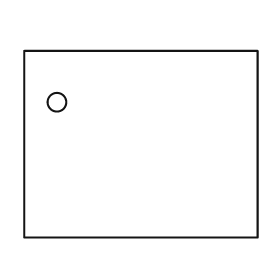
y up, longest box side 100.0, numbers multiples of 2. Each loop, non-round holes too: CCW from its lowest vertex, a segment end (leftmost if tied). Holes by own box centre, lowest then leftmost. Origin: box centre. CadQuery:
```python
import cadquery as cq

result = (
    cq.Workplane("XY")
    .moveTo(-50.0, -40.0)
    .lineTo(50.0, -40.0)
    .lineTo(50.0, 40.0)
    .lineTo(-50.0, 40.0)
    .close()
    .moveTo(-36.0, 18.0)
    .circle(4.0)
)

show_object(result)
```